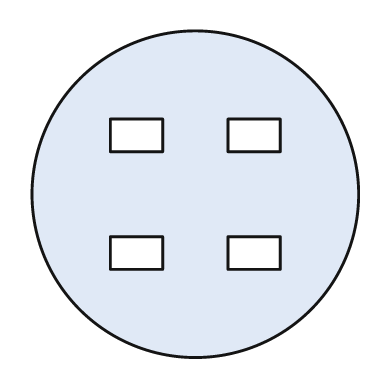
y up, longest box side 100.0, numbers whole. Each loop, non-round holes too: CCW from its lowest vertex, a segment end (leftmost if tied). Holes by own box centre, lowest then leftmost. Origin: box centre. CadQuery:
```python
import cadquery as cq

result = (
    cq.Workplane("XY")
    .moveTo(0.0, 0.0)
    .circle(50.0)
    .moveTo(-26.0, -23.0)
    .lineTo(-10.0, -23.0)
    .lineTo(-10.0, -13.0)
    .lineTo(-26.0, -13.0)
    .close()
    .moveTo(10.0, -23.0)
    .lineTo(26.0, -23.0)
    .lineTo(26.0, -13.0)
    .lineTo(10.0, -13.0)
    .close()
    .moveTo(-26.0, 13.0)
    .lineTo(-10.0, 13.0)
    .lineTo(-10.0, 23.0)
    .lineTo(-26.0, 23.0)
    .close()
    .moveTo(10.0, 13.0)
    .lineTo(26.0, 13.0)
    .lineTo(26.0, 23.0)
    .lineTo(10.0, 23.0)
    .close()
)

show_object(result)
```